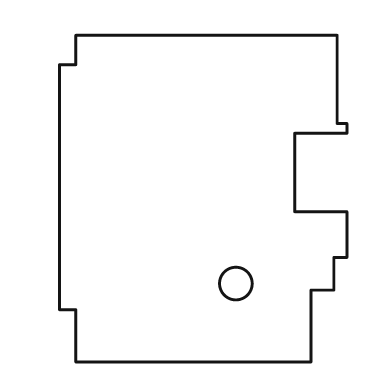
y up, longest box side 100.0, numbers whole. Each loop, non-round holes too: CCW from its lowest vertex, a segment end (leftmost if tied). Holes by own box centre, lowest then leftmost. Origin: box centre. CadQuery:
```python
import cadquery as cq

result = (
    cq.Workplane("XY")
    .moveTo(-39.0, -50.0)
    .lineTo(33.0, -50.0)
    .lineTo(33.0, -28.0)
    .lineTo(40.0, -28.0)
    .lineTo(40.0, -18.0)
    .lineTo(44.0, -18.0)
    .lineTo(44.0, -4.0)
    .lineTo(28.0, -4.0)
    .lineTo(28.0, 20.0)
    .lineTo(44.0, 20.0)
    .lineTo(44.0, 23.0)
    .lineTo(41.0, 23.0)
    .lineTo(41.0, 50.0)
    .lineTo(-39.0, 50.0)
    .lineTo(-39.0, 41.0)
    .lineTo(-44.0, 41.0)
    .lineTo(-44.0, -34.0)
    .lineTo(-39.0, -34.0)
    .close()
    .moveTo(10.0, -26.0)
    .circle(5.0)
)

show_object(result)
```